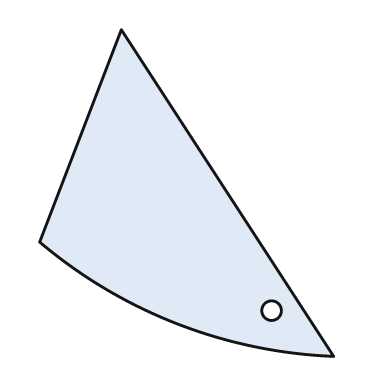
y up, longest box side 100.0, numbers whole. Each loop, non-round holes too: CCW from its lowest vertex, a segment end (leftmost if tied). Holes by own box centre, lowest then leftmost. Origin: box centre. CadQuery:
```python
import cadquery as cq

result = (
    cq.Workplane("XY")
    .moveTo(45.0, -50.0)
    .lineTo(-20.0, 50.0)
    .lineTo(-45.0, -15.0)
    .threePointArc((-3.0, -40.0), (45.0, -50.0))
    .close()
    .moveTo(26.0, -36.0)
    .circle(3.0)
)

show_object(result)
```